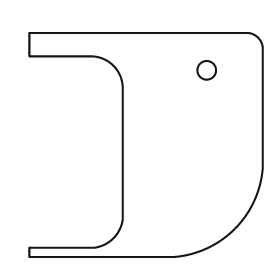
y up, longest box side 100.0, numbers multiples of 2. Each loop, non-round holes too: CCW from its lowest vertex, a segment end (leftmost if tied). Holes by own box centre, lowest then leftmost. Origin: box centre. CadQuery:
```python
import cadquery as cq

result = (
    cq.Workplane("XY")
    .moveTo(-50.0, -48.0)
    .lineTo(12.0, -48.0)
    .threePointArc((38.0, -36.0), (50.0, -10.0))
    .lineTo(50.0, 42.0)
    .threePointArc((48.0, 46.0), (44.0, 48.0))
    .lineTo(-50.0, 48.0)
    .lineTo(-50.0, 38.0)
    .lineTo(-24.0, 38.0)
    .threePointArc((-14.0, 34.0), (-10.0, 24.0))
    .lineTo(-10.0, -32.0)
    .threePointArc((-14.0, -40.0), (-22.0, -44.0))
    .lineTo(-50.0, -44.0)
    .close()
    .moveTo(26.0, 32.0)
    .circle(4.0)
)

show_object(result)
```